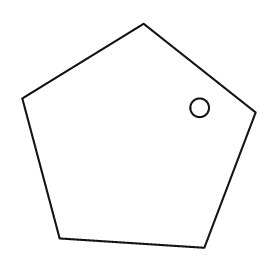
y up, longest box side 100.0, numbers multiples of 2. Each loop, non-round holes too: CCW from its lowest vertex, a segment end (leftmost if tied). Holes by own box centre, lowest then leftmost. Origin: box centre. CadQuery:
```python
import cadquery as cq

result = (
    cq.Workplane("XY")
    .moveTo(28.0, -48.0)
    .lineTo(50.0, 10.0)
    .lineTo(2.0, 48.0)
    .lineTo(-50.0, 16.0)
    .lineTo(-34.0, -44.0)
    .close()
    .moveTo(26.0, 12.0)
    .circle(4.0)
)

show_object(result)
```